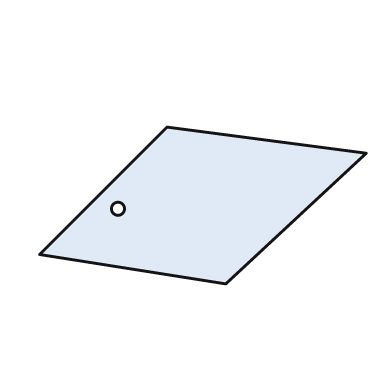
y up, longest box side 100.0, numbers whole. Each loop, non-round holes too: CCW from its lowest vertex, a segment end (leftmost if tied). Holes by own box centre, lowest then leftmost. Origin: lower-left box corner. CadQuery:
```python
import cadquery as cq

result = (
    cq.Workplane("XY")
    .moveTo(57.0, 0.0)
    .lineTo(100.0, 40.0)
    .lineTo(39.0, 48.0)
    .lineTo(0.0, 9.0)
    .close()
    .moveTo(24.0, 23.0)
    .circle(2.0)
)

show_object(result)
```